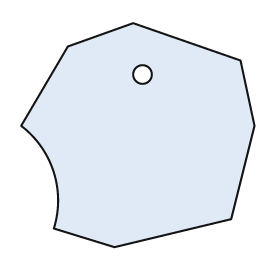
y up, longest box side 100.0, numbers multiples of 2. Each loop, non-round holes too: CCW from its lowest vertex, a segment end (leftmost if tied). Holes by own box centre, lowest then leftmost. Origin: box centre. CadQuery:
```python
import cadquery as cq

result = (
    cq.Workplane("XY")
    .moveTo(-10.0, -48.0)
    .lineTo(40.0, -36.0)
    .lineTo(50.0, 4.0)
    .lineTo(44.0, 32.0)
    .lineTo(-2.0, 48.0)
    .lineTo(-30.0, 38.0)
    .lineTo(-50.0, 4.0)
    .threePointArc((-36.0, -16.0), (-36.0, -40.0))
    .close()
    .moveTo(2.0, 26.0)
    .circle(4.0)
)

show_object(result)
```